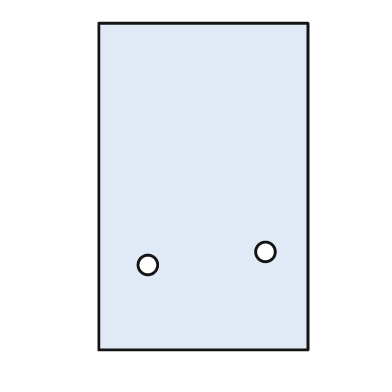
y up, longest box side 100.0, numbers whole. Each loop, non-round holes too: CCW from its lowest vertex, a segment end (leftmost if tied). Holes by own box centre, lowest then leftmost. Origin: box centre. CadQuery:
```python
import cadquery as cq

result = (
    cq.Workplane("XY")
    .moveTo(-32.0, -50.0)
    .lineTo(32.0, -50.0)
    .lineTo(32.0, 50.0)
    .lineTo(-32.0, 50.0)
    .close()
    .moveTo(-17.0, -24.0)
    .circle(3.0)
    .moveTo(19.0, -20.0)
    .circle(3.0)
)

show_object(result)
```